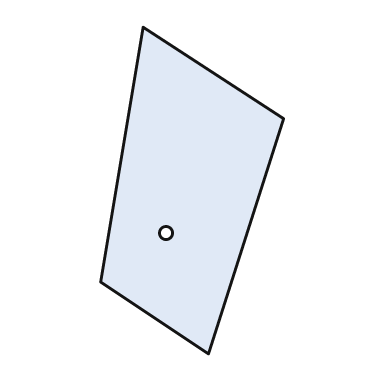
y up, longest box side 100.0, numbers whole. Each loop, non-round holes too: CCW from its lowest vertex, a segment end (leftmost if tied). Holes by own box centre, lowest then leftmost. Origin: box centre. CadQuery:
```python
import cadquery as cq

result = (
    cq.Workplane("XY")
    .moveTo(5.0, -50.0)
    .lineTo(28.0, 22.0)
    .lineTo(-15.0, 50.0)
    .lineTo(-28.0, -28.0)
    .close()
    .moveTo(-8.0, -13.0)
    .circle(2.0)
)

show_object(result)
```